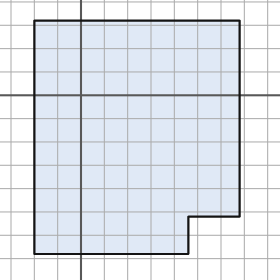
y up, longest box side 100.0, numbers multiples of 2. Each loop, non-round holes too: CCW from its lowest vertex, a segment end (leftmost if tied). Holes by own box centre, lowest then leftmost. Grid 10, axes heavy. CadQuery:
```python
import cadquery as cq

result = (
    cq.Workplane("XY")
    .moveTo(-20.0, -68.0)
    .lineTo(46.0, -68.0)
    .lineTo(46.0, -52.0)
    .lineTo(68.0, -52.0)
    .lineTo(68.0, 32.0)
    .lineTo(-20.0, 32.0)
    .close()
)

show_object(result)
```